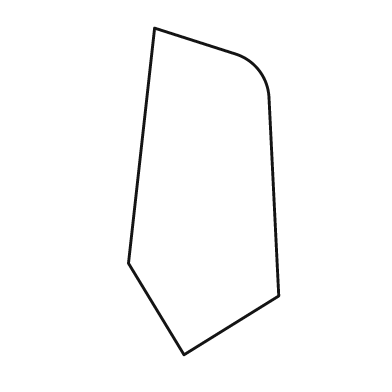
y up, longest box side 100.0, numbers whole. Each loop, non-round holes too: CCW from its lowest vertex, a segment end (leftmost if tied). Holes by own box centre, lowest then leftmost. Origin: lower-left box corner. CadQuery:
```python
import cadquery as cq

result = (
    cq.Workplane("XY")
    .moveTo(17.0, 0.0)
    .lineTo(46.0, 18.0)
    .lineTo(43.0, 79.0)
    .threePointArc((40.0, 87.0), (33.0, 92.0))
    .lineTo(8.0, 100.0)
    .lineTo(0.0, 28.0)
    .close()
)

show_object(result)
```